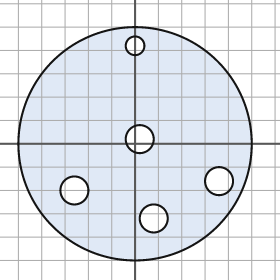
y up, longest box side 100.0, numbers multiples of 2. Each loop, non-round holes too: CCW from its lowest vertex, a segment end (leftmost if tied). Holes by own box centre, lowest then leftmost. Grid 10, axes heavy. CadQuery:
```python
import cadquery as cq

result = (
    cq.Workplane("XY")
    .moveTo(0.0, 0.0)
    .circle(50.0)
    .moveTo(8.0, -32.0)
    .circle(6.0)
    .moveTo(-26.0, -20.0)
    .circle(6.0)
    .moveTo(36.0, -16.0)
    .circle(6.0)
    .moveTo(2.0, 2.0)
    .circle(6.0)
    .moveTo(0.0, 42.0)
    .circle(4.0)
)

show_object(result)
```